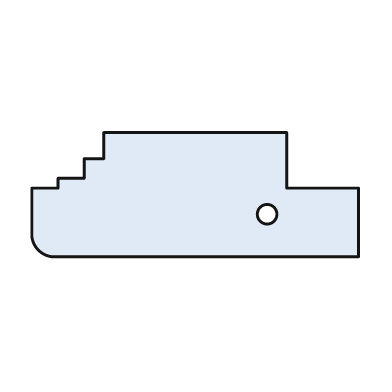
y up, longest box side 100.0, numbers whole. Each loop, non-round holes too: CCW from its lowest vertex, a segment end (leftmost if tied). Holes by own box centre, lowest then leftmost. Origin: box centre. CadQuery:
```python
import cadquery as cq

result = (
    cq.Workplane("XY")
    .moveTo(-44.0, -19.0)
    .lineTo(50.0, -19.0)
    .lineTo(50.0, 2.0)
    .lineTo(28.0, 2.0)
    .lineTo(28.0, 19.0)
    .lineTo(-28.0, 19.0)
    .lineTo(-28.0, 11.0)
    .lineTo(-34.0, 11.0)
    .lineTo(-34.0, 5.0)
    .lineTo(-42.0, 5.0)
    .lineTo(-42.0, 2.0)
    .lineTo(-50.0, 2.0)
    .lineTo(-50.0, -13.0)
    .threePointArc((-48.0, -17.0), (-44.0, -19.0))
    .close()
    .moveTo(22.0, -6.0)
    .circle(3.0)
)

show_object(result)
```